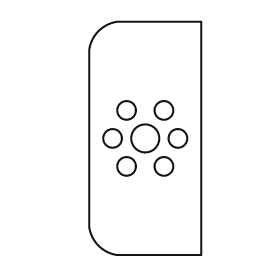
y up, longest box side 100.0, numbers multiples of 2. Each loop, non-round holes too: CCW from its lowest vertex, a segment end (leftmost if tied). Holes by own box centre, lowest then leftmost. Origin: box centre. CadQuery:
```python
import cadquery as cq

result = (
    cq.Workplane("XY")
    .moveTo(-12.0, -50.0)
    .lineTo(24.0, -50.0)
    .lineTo(24.0, 50.0)
    .lineTo(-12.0, 50.0)
    .threePointArc((-20.0, 46.0), (-24.0, 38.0))
    .lineTo(-24.0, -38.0)
    .threePointArc((-20.0, -46.0), (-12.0, -50.0))
    .close()
    .moveTo(-8.0, -12.0)
    .circle(4.0)
    .moveTo(8.0, -12.0)
    .circle(4.0)
    .moveTo(-14.0, 0.0)
    .circle(4.0)
    .moveTo(0.0, 0.0)
    .circle(6.0)
    .moveTo(14.0, 0.0)
    .circle(4.0)
    .moveTo(-8.0, 12.0)
    .circle(4.0)
    .moveTo(8.0, 12.0)
    .circle(4.0)
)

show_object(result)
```